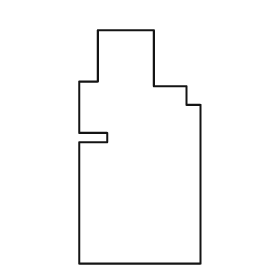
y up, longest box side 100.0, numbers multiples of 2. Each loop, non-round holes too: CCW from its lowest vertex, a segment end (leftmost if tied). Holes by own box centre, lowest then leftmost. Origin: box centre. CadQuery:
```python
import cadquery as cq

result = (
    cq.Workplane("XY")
    .moveTo(-26.0, -50.0)
    .lineTo(26.0, -50.0)
    .lineTo(26.0, 18.0)
    .lineTo(20.0, 18.0)
    .lineTo(20.0, 26.0)
    .lineTo(6.0, 26.0)
    .lineTo(6.0, 50.0)
    .lineTo(-18.0, 50.0)
    .lineTo(-18.0, 28.0)
    .lineTo(-26.0, 28.0)
    .lineTo(-26.0, 6.0)
    .lineTo(-14.0, 6.0)
    .lineTo(-14.0, 2.0)
    .lineTo(-26.0, 2.0)
    .close()
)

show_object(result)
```